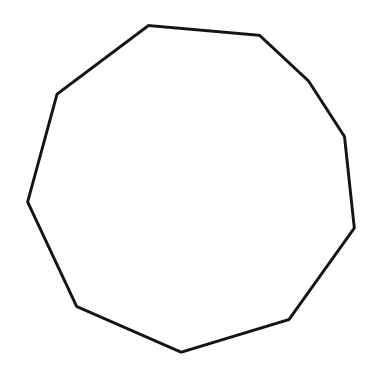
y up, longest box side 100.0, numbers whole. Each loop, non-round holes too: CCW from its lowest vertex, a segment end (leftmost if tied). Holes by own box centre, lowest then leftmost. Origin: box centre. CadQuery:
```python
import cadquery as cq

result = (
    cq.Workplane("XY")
    .moveTo(-3.0, -50.0)
    .lineTo(30.0, -40.0)
    .lineTo(50.0, -12.0)
    .lineTo(47.0, 16.0)
    .lineTo(36.0, 33.0)
    .lineTo(21.0, 47.0)
    .lineTo(-13.0, 50.0)
    .lineTo(-41.0, 29.0)
    .lineTo(-50.0, -4.0)
    .lineTo(-35.0, -36.0)
    .close()
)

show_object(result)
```